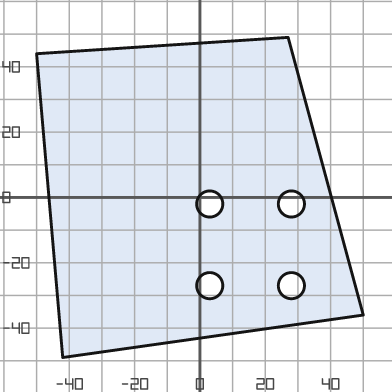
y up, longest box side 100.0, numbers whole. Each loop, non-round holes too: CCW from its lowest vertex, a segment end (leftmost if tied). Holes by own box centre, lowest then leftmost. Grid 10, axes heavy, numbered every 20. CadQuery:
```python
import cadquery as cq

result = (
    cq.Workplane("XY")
    .moveTo(-42.0, -49.0)
    .lineTo(50.0, -36.0)
    .lineTo(27.0, 49.0)
    .lineTo(-50.0, 44.0)
    .close()
    .moveTo(3.0, -27.0)
    .circle(4.0)
    .moveTo(28.0, -27.0)
    .circle(4.0)
    .moveTo(3.0, -2.0)
    .circle(4.0)
    .moveTo(28.0, -2.0)
    .circle(4.0)
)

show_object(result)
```